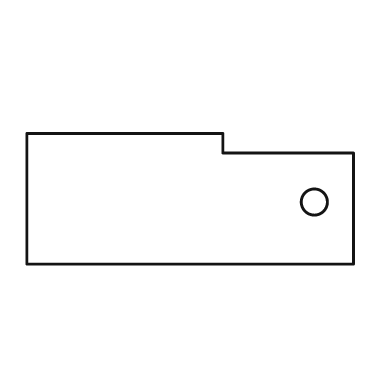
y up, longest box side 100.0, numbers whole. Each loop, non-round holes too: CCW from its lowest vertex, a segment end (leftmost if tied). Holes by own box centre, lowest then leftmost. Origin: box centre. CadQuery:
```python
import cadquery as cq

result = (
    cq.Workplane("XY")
    .moveTo(-50.0, -20.0)
    .lineTo(50.0, -20.0)
    .lineTo(50.0, 14.0)
    .lineTo(10.0, 14.0)
    .lineTo(10.0, 20.0)
    .lineTo(-50.0, 20.0)
    .close()
    .moveTo(38.0, -1.0)
    .circle(4.0)
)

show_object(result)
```